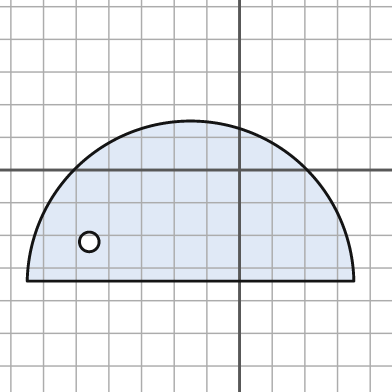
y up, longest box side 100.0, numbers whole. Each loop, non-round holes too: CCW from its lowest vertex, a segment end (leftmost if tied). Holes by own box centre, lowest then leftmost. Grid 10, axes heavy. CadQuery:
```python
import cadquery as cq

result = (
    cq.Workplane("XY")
    .moveTo(-65.0, -34.0)
    .lineTo(35.0, -34.0)
    .threePointArc((-15.0, 15.0), (-65.0, -34.0))
    .close()
    .moveTo(-46.0, -22.0)
    .circle(3.0)
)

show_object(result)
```